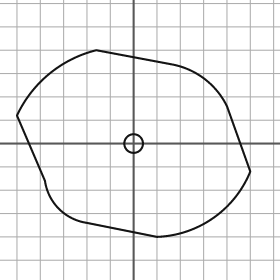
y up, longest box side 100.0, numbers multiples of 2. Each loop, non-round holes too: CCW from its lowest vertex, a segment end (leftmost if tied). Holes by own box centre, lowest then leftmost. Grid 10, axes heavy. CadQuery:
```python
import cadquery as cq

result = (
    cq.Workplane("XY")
    .moveTo(10.0, -40.0)
    .threePointArc((34.0, -32.0), (50.0, -12.0))
    .lineTo(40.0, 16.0)
    .threePointArc((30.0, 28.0), (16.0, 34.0))
    .lineTo(-16.0, 40.0)
    .threePointArc((-36.0, 30.0), (-50.0, 12.0))
    .lineTo(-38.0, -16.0)
    .threePointArc((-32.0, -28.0), (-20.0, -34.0))
    .close()
    .moveTo(0.0, 0.0)
    .circle(4.0)
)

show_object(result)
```